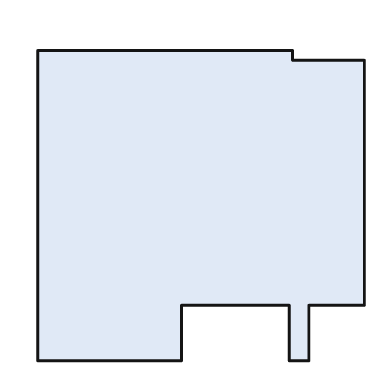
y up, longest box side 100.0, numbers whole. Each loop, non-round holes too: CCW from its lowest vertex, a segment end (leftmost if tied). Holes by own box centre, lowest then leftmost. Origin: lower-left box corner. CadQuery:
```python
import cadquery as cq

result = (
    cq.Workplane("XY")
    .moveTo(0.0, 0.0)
    .lineTo(44.0, 0.0)
    .lineTo(44.0, 17.0)
    .lineTo(77.0, 17.0)
    .lineTo(77.0, 0.0)
    .lineTo(83.0, 0.0)
    .lineTo(83.0, 17.0)
    .lineTo(100.0, 17.0)
    .lineTo(100.0, 92.0)
    .lineTo(78.0, 92.0)
    .lineTo(78.0, 95.0)
    .lineTo(0.0, 95.0)
    .close()
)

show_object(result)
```